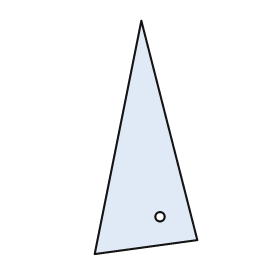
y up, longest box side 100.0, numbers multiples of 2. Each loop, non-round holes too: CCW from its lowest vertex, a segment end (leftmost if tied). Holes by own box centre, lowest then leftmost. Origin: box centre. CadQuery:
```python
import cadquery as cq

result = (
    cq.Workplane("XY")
    .moveTo(-22.0, -50.0)
    .lineTo(22.0, -44.0)
    .lineTo(-2.0, 50.0)
    .close()
    .moveTo(6.0, -34.0)
    .circle(2.0)
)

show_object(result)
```